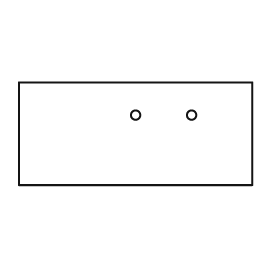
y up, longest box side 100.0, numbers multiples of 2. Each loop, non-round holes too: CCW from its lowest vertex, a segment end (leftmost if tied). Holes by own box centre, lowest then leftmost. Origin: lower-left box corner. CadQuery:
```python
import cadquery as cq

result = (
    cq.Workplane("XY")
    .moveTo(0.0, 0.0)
    .lineTo(100.0, 0.0)
    .lineTo(100.0, 44.0)
    .lineTo(0.0, 44.0)
    .close()
    .moveTo(50.0, 30.0)
    .circle(2.0)
    .moveTo(74.0, 30.0)
    .circle(2.0)
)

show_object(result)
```